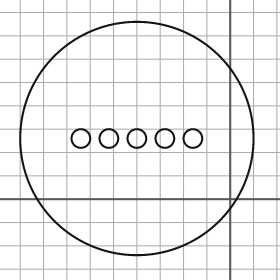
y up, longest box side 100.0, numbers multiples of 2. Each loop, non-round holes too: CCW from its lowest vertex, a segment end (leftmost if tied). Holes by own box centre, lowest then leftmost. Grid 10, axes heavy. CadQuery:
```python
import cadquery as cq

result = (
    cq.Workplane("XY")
    .moveTo(-40.0, 26.0)
    .circle(50.0)
    .moveTo(-64.0, 26.0)
    .circle(4.0)
    .moveTo(-52.0, 26.0)
    .circle(4.0)
    .moveTo(-40.0, 26.0)
    .circle(4.0)
    .moveTo(-28.0, 26.0)
    .circle(4.0)
    .moveTo(-16.0, 26.0)
    .circle(4.0)
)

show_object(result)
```